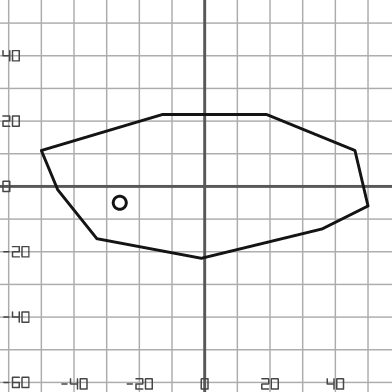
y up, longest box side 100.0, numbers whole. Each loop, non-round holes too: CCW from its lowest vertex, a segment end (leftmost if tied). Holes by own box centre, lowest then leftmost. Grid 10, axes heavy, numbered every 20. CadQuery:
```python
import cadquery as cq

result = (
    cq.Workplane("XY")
    .moveTo(-1.0, -22.0)
    .lineTo(36.0, -13.0)
    .lineTo(50.0, -6.0)
    .lineTo(46.0, 11.0)
    .lineTo(19.0, 22.0)
    .lineTo(-13.0, 22.0)
    .lineTo(-50.0, 11.0)
    .lineTo(-45.0, -1.0)
    .lineTo(-33.0, -16.0)
    .close()
    .moveTo(-26.0, -5.0)
    .circle(2.0)
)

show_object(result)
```